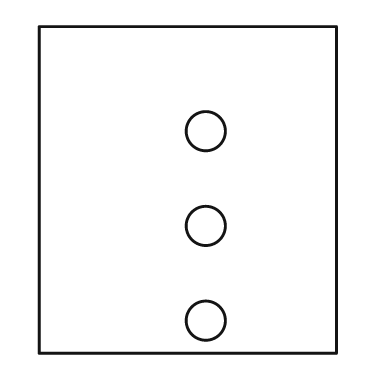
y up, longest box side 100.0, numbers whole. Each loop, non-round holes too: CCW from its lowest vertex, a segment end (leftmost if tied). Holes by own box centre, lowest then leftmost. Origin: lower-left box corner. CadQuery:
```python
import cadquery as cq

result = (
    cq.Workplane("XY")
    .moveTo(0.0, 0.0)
    .lineTo(91.0, 0.0)
    .lineTo(91.0, 100.0)
    .lineTo(0.0, 100.0)
    .close()
    .moveTo(51.0, 10.0)
    .circle(6.0)
    .moveTo(51.0, 39.0)
    .circle(6.0)
    .moveTo(51.0, 68.0)
    .circle(6.0)
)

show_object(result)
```